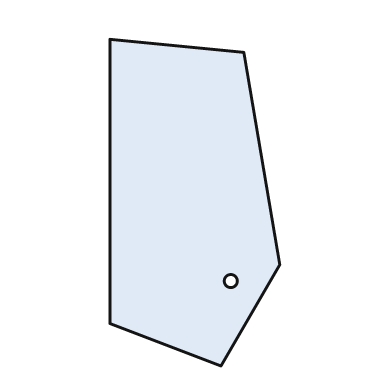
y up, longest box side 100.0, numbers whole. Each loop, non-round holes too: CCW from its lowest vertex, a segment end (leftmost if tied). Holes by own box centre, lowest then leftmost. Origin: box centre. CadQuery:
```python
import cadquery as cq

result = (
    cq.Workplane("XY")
    .moveTo(8.0, -50.0)
    .lineTo(26.0, -19.0)
    .lineTo(15.0, 46.0)
    .lineTo(-26.0, 50.0)
    .lineTo(-26.0, -37.0)
    .close()
    .moveTo(11.0, -24.0)
    .circle(2.0)
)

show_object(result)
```